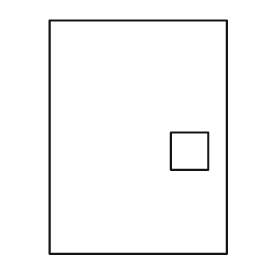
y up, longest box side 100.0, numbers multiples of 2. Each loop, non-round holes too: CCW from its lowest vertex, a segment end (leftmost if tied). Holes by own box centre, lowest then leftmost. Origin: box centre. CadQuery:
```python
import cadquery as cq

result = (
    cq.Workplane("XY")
    .moveTo(-38.0, -50.0)
    .lineTo(38.0, -50.0)
    .lineTo(38.0, 50.0)
    .lineTo(-38.0, 50.0)
    .close()
    .moveTo(14.0, -14.0)
    .lineTo(30.0, -14.0)
    .lineTo(30.0, 2.0)
    .lineTo(14.0, 2.0)
    .close()
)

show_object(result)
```